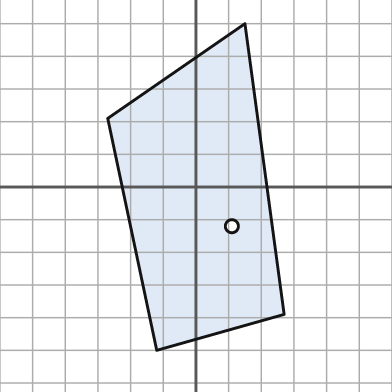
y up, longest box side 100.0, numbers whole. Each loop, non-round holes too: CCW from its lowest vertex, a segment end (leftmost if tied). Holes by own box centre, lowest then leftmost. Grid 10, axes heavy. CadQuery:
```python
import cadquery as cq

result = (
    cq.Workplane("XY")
    .moveTo(-12.0, -50.0)
    .lineTo(27.0, -39.0)
    .lineTo(15.0, 50.0)
    .lineTo(-27.0, 21.0)
    .close()
    .moveTo(11.0, -12.0)
    .circle(2.0)
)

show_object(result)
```